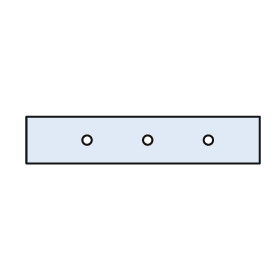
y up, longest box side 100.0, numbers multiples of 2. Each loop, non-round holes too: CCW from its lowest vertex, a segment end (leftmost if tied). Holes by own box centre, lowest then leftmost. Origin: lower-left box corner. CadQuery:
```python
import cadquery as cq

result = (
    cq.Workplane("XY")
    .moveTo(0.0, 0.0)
    .lineTo(100.0, 0.0)
    .lineTo(100.0, 20.0)
    .lineTo(0.0, 20.0)
    .close()
    .moveTo(26.0, 10.0)
    .circle(2.0)
    .moveTo(52.0, 10.0)
    .circle(2.0)
    .moveTo(78.0, 10.0)
    .circle(2.0)
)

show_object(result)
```